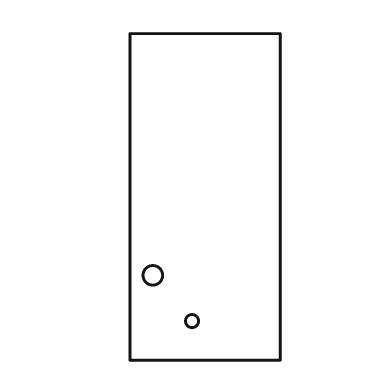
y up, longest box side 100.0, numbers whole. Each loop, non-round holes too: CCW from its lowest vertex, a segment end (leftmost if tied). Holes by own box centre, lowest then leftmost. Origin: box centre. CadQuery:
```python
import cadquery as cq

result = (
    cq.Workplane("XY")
    .moveTo(-23.0, -50.0)
    .lineTo(23.0, -50.0)
    .lineTo(23.0, 50.0)
    .lineTo(-23.0, 50.0)
    .close()
    .moveTo(-4.0, -38.0)
    .circle(2.0)
    .moveTo(-16.0, -24.0)
    .circle(3.0)
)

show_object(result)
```